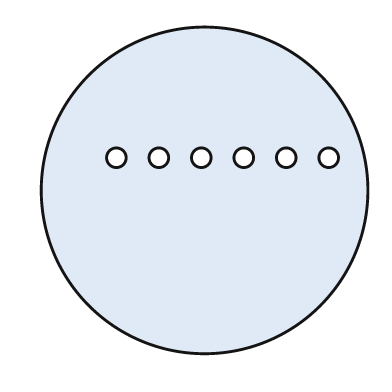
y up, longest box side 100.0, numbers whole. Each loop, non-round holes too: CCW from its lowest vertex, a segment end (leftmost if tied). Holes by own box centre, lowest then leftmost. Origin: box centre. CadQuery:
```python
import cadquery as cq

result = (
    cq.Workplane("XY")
    .moveTo(0.0, 0.0)
    .circle(50.0)
    .moveTo(-27.0, 10.0)
    .circle(3.0)
    .moveTo(-14.0, 10.0)
    .circle(3.0)
    .moveTo(-1.0, 10.0)
    .circle(3.0)
    .moveTo(12.0, 10.0)
    .circle(3.0)
    .moveTo(25.0, 10.0)
    .circle(3.0)
    .moveTo(38.0, 10.0)
    .circle(3.0)
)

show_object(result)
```